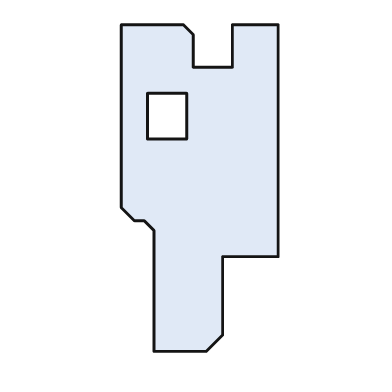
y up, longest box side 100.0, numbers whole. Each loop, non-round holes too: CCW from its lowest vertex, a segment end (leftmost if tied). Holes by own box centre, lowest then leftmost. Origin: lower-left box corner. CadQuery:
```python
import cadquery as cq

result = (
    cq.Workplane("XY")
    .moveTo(10.0, 0.0)
    .lineTo(26.0, 0.0)
    .lineTo(31.0, 5.0)
    .lineTo(31.0, 29.0)
    .lineTo(48.0, 29.0)
    .lineTo(48.0, 100.0)
    .lineTo(34.0, 100.0)
    .lineTo(34.0, 87.0)
    .lineTo(22.0, 87.0)
    .lineTo(22.0, 97.0)
    .lineTo(19.0, 100.0)
    .lineTo(0.0, 100.0)
    .lineTo(0.0, 44.0)
    .lineTo(4.0, 40.0)
    .lineTo(7.0, 40.0)
    .lineTo(10.0, 37.0)
    .close()
    .moveTo(8.0, 65.0)
    .lineTo(20.0, 65.0)
    .lineTo(20.0, 79.0)
    .lineTo(8.0, 79.0)
    .close()
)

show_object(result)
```